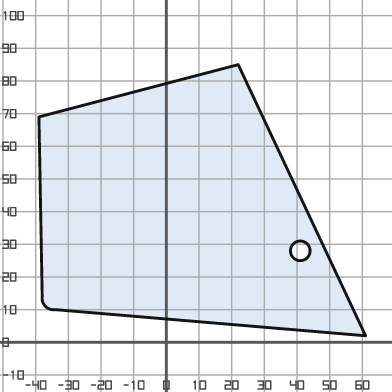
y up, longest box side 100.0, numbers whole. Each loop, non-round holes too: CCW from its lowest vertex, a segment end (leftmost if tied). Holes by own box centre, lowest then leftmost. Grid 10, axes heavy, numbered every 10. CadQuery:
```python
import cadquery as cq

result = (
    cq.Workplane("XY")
    .moveTo(61.0, 2.0)
    .lineTo(22.0, 85.0)
    .lineTo(-39.0, 69.0)
    .lineTo(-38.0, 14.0)
    .threePointArc((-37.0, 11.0), (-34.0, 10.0))
    .close()
    .moveTo(41.0, 28.0)
    .circle(3.0)
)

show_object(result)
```